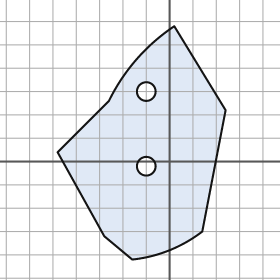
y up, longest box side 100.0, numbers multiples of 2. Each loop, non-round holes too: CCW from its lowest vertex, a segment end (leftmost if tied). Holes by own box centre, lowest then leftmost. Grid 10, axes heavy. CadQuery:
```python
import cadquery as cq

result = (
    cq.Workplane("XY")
    .moveTo(-16.0, -42.0)
    .threePointArc((0.0, -38.0), (14.0, -30.0))
    .lineTo(24.0, 22.0)
    .lineTo(2.0, 58.0)
    .threePointArc((-14.0, 44.0), (-26.0, 26.0))
    .lineTo(-48.0, 4.0)
    .lineTo(-28.0, -32.0)
    .close()
    .moveTo(-10.0, -2.0)
    .circle(4.0)
    .moveTo(-10.0, 30.0)
    .circle(4.0)
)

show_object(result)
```